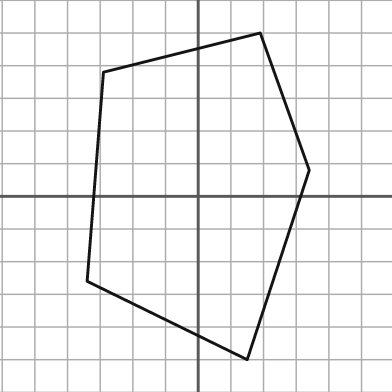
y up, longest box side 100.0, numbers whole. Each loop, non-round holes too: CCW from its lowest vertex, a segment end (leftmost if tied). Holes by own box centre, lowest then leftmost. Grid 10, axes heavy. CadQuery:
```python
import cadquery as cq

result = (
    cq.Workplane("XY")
    .moveTo(15.0, -50.0)
    .lineTo(34.0, 8.0)
    .lineTo(19.0, 50.0)
    .lineTo(-29.0, 38.0)
    .lineTo(-34.0, -26.0)
    .close()
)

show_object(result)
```